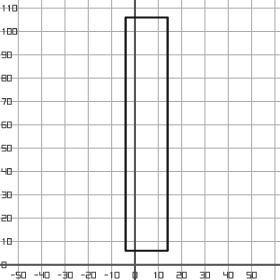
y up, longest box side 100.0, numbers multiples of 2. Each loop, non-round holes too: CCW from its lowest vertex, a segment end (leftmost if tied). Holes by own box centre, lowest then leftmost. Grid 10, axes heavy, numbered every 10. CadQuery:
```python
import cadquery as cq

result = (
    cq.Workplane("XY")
    .moveTo(-4.0, 6.0)
    .lineTo(14.0, 6.0)
    .lineTo(14.0, 106.0)
    .lineTo(-4.0, 106.0)
    .close()
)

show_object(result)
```